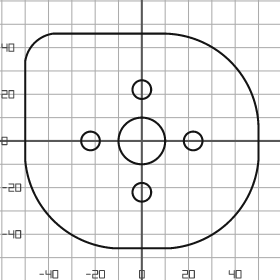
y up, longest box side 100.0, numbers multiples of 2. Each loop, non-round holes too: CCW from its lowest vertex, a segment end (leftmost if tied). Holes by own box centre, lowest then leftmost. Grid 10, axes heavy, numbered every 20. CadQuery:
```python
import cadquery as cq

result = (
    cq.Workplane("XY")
    .moveTo(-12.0, -46.0)
    .lineTo(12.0, -46.0)
    .threePointArc((38.0, -34.0), (50.0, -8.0))
    .lineTo(50.0, 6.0)
    .threePointArc((38.0, 34.0), (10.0, 46.0))
    .lineTo(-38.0, 46.0)
    .threePointArc((-46.0, 42.0), (-50.0, 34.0))
    .lineTo(-50.0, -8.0)
    .threePointArc((-38.0, -34.0), (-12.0, -46.0))
    .close()
    .moveTo(0.0, -22.0)
    .circle(4.0)
    .moveTo(-22.0, 0.0)
    .circle(4.0)
    .moveTo(0.0, 0.0)
    .circle(10.0)
    .moveTo(22.0, 0.0)
    .circle(4.0)
    .moveTo(0.0, 22.0)
    .circle(4.0)
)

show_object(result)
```